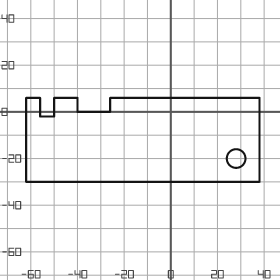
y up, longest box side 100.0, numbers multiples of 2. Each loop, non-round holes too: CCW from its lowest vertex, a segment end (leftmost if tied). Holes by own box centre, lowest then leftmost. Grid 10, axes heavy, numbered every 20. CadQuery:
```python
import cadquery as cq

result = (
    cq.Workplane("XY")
    .moveTo(-62.0, -30.0)
    .lineTo(38.0, -30.0)
    .lineTo(38.0, 6.0)
    .lineTo(-26.0, 6.0)
    .lineTo(-26.0, 0.0)
    .lineTo(-40.0, 0.0)
    .lineTo(-40.0, 6.0)
    .lineTo(-50.0, 6.0)
    .lineTo(-50.0, -2.0)
    .lineTo(-56.0, -2.0)
    .lineTo(-56.0, 6.0)
    .lineTo(-62.0, 6.0)
    .close()
    .moveTo(28.0, -20.0)
    .circle(4.0)
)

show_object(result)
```